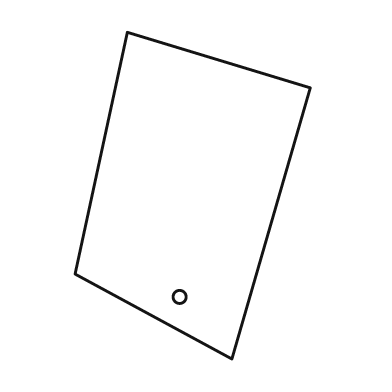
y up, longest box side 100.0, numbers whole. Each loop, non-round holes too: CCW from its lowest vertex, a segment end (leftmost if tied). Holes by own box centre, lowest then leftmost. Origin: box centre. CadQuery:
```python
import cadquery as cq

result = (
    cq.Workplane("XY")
    .moveTo(12.0, -50.0)
    .lineTo(36.0, 33.0)
    .lineTo(-20.0, 50.0)
    .lineTo(-36.0, -24.0)
    .close()
    .moveTo(-4.0, -31.0)
    .circle(2.0)
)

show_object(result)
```